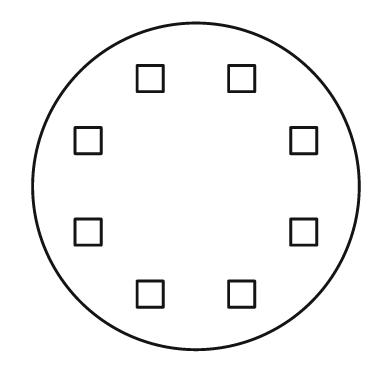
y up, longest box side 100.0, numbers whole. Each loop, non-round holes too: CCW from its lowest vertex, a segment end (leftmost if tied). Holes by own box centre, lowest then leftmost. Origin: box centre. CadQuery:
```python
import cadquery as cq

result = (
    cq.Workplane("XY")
    .moveTo(0.0, 0.0)
    .circle(50.0)
    .moveTo(-18.0, -37.0)
    .lineTo(-10.0, -37.0)
    .lineTo(-10.0, -29.0)
    .lineTo(-18.0, -29.0)
    .close()
    .moveTo(10.0, -37.0)
    .lineTo(18.0, -37.0)
    .lineTo(18.0, -29.0)
    .lineTo(10.0, -29.0)
    .close()
    .moveTo(-37.0, -18.0)
    .lineTo(-29.0, -18.0)
    .lineTo(-29.0, -10.0)
    .lineTo(-37.0, -10.0)
    .close()
    .moveTo(29.0, -18.0)
    .lineTo(37.0, -18.0)
    .lineTo(37.0, -10.0)
    .lineTo(29.0, -10.0)
    .close()
    .moveTo(-37.0, 10.0)
    .lineTo(-29.0, 10.0)
    .lineTo(-29.0, 18.0)
    .lineTo(-37.0, 18.0)
    .close()
    .moveTo(29.0, 10.0)
    .lineTo(37.0, 10.0)
    .lineTo(37.0, 18.0)
    .lineTo(29.0, 18.0)
    .close()
    .moveTo(-18.0, 29.0)
    .lineTo(-10.0, 29.0)
    .lineTo(-10.0, 37.0)
    .lineTo(-18.0, 37.0)
    .close()
    .moveTo(10.0, 29.0)
    .lineTo(18.0, 29.0)
    .lineTo(18.0, 37.0)
    .lineTo(10.0, 37.0)
    .close()
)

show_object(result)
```